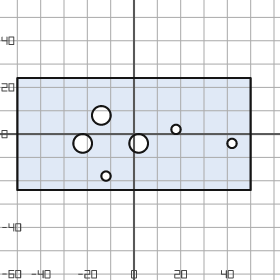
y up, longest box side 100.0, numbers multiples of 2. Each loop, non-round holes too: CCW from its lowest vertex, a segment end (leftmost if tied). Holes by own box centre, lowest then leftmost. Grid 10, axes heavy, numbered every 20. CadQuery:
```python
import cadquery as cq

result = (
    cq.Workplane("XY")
    .moveTo(-50.0, -24.0)
    .lineTo(50.0, -24.0)
    .lineTo(50.0, 24.0)
    .lineTo(-50.0, 24.0)
    .close()
    .moveTo(-12.0, -18.0)
    .circle(2.0)
    .moveTo(-22.0, -4.0)
    .circle(4.0)
    .moveTo(2.0, -4.0)
    .circle(4.0)
    .moveTo(42.0, -4.0)
    .circle(2.0)
    .moveTo(18.0, 2.0)
    .circle(2.0)
    .moveTo(-14.0, 8.0)
    .circle(4.0)
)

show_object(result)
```